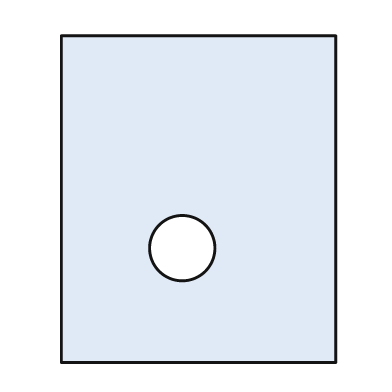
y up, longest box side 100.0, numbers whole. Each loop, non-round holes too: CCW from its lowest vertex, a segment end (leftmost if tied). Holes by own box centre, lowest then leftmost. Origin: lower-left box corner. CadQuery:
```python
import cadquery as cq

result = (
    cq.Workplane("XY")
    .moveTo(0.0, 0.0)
    .lineTo(84.0, 0.0)
    .lineTo(84.0, 100.0)
    .lineTo(0.0, 100.0)
    .close()
    .moveTo(37.0, 35.0)
    .circle(10.0)
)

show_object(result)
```